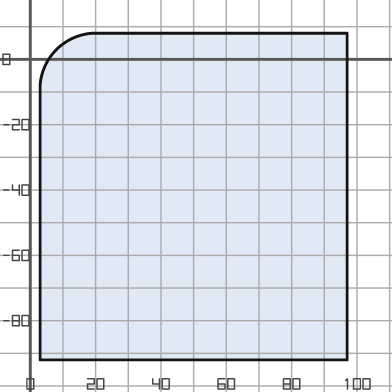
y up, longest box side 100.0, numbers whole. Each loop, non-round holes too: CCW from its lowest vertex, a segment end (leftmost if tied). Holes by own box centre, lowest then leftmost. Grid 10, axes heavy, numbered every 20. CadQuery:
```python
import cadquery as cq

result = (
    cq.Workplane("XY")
    .moveTo(3.0, -92.0)
    .lineTo(97.0, -92.0)
    .lineTo(97.0, 8.0)
    .lineTo(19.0, 8.0)
    .threePointArc((8.0, 3.0), (3.0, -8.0))
    .close()
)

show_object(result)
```